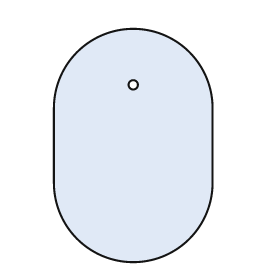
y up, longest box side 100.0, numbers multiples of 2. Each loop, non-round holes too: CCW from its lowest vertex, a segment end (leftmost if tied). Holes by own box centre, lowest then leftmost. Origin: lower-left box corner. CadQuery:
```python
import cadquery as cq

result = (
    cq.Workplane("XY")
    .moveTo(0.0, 34.0)
    .threePointArc((34.0, 0.0), (68.0, 34.0))
    .lineTo(68.0, 66.0)
    .threePointArc((34.0, 100.0), (0.0, 66.0))
    .close()
    .moveTo(34.0, 76.0)
    .circle(2.0)
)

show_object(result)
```